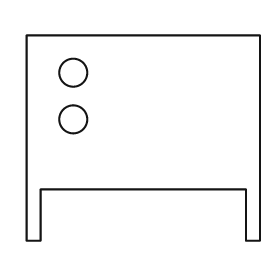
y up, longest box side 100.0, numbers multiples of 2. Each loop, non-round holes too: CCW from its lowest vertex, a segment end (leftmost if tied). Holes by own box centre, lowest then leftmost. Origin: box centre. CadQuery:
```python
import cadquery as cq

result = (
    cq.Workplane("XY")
    .moveTo(-50.0, -44.0)
    .lineTo(-44.0, -44.0)
    .lineTo(-44.0, -22.0)
    .lineTo(44.0, -22.0)
    .lineTo(44.0, -44.0)
    .lineTo(50.0, -44.0)
    .lineTo(50.0, 44.0)
    .lineTo(-50.0, 44.0)
    .close()
    .moveTo(-30.0, 8.0)
    .circle(6.0)
    .moveTo(-30.0, 28.0)
    .circle(6.0)
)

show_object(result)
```